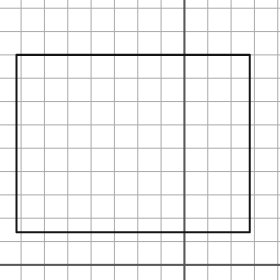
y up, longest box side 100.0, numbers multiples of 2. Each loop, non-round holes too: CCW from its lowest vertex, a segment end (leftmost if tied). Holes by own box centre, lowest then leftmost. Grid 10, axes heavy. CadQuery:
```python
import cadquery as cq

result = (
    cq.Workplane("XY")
    .moveTo(-72.0, 14.0)
    .lineTo(28.0, 14.0)
    .lineTo(28.0, 90.0)
    .lineTo(-72.0, 90.0)
    .close()
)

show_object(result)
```